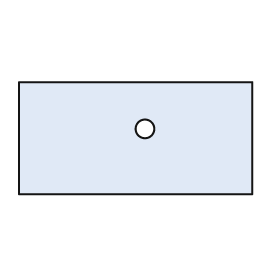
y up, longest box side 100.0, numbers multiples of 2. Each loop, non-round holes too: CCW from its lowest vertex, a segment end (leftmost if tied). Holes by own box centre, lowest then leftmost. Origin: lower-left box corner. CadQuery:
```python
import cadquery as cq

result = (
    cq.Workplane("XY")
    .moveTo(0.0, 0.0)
    .lineTo(100.0, 0.0)
    .lineTo(100.0, 48.0)
    .lineTo(0.0, 48.0)
    .close()
    .moveTo(54.0, 28.0)
    .circle(4.0)
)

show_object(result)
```